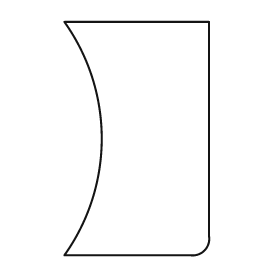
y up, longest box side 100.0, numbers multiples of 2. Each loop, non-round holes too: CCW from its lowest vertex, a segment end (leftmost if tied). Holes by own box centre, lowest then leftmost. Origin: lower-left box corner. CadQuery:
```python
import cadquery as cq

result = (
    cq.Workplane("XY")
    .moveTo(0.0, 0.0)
    .lineTo(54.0, 0.0)
    .threePointArc((60.0, 2.0), (62.0, 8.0))
    .lineTo(62.0, 100.0)
    .lineTo(0.0, 100.0)
    .threePointArc((16.0, 50.0), (0.0, 0.0))
    .close()
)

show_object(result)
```